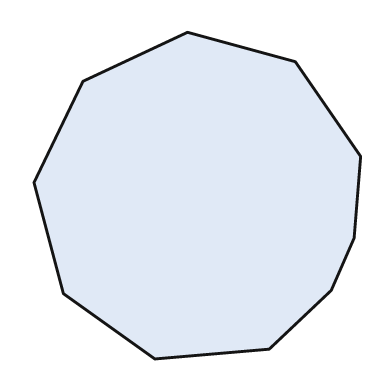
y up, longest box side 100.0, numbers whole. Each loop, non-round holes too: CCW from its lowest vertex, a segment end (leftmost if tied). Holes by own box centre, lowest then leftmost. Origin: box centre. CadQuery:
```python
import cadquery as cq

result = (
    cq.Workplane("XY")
    .moveTo(-13.0, -50.0)
    .lineTo(22.0, -47.0)
    .lineTo(41.0, -29.0)
    .lineTo(48.0, -13.0)
    .lineTo(50.0, 12.0)
    .lineTo(30.0, 41.0)
    .lineTo(-3.0, 50.0)
    .lineTo(-35.0, 35.0)
    .lineTo(-50.0, 4.0)
    .lineTo(-41.0, -30.0)
    .close()
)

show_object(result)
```